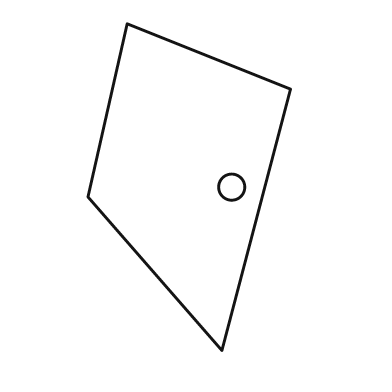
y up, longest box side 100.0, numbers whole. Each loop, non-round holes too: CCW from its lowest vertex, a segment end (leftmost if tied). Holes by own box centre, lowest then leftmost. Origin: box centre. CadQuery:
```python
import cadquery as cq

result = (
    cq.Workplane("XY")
    .moveTo(10.0, -50.0)
    .lineTo(31.0, 30.0)
    .lineTo(-19.0, 50.0)
    .lineTo(-31.0, -3.0)
    .close()
    .moveTo(13.0, 0.0)
    .circle(4.0)
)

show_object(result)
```